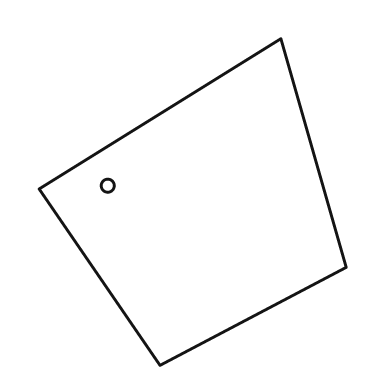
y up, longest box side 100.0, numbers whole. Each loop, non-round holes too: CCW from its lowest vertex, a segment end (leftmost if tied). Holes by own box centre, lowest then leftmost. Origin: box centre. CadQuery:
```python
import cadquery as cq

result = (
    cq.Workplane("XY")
    .moveTo(-10.0, -50.0)
    .lineTo(47.0, -20.0)
    .lineTo(27.0, 50.0)
    .lineTo(-47.0, 4.0)
    .close()
    .moveTo(-26.0, 5.0)
    .circle(2.0)
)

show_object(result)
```